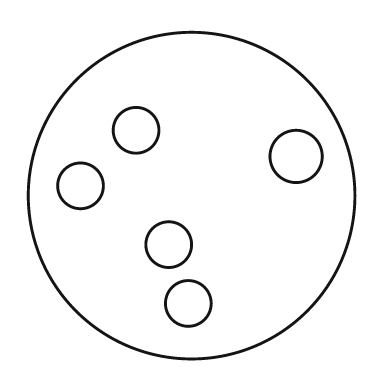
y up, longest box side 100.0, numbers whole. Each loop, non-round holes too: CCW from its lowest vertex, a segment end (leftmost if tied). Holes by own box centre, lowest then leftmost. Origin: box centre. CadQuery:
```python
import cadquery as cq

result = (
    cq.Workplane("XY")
    .moveTo(0.0, 0.0)
    .circle(50.0)
    .moveTo(-1.0, -33.0)
    .circle(7.0)
    .moveTo(-7.0, -15.0)
    .circle(7.0)
    .moveTo(-34.0, 3.0)
    .circle(7.0)
    .moveTo(32.0, 12.0)
    .circle(8.0)
    .moveTo(-17.0, 20.0)
    .circle(7.0)
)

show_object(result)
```